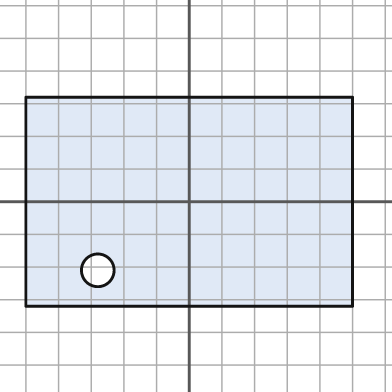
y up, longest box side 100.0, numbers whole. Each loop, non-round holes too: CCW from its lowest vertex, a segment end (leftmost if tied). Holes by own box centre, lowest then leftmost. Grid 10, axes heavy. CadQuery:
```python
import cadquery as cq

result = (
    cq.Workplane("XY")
    .moveTo(-50.0, -32.0)
    .lineTo(50.0, -32.0)
    .lineTo(50.0, 32.0)
    .lineTo(-50.0, 32.0)
    .close()
    .moveTo(-28.0, -21.0)
    .circle(5.0)
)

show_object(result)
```